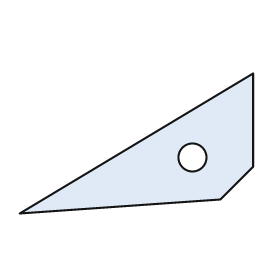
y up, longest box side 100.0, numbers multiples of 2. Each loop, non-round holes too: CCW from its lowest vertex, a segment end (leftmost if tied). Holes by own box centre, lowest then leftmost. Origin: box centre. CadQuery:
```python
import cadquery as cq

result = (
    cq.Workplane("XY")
    .moveTo(-50.0, -30.0)
    .lineTo(36.0, -24.0)
    .lineTo(50.0, -10.0)
    .lineTo(50.0, 30.0)
    .close()
    .moveTo(24.0, -6.0)
    .circle(6.0)
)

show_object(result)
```